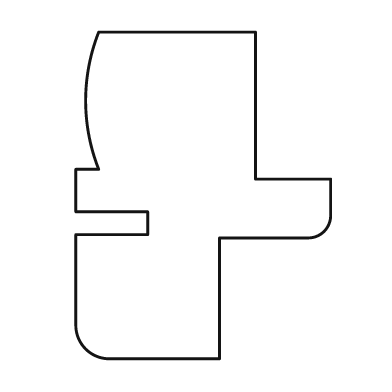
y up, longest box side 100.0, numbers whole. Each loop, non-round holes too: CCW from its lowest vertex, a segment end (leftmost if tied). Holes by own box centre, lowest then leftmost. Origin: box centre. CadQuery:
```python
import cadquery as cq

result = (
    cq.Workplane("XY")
    .moveTo(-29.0, -50.0)
    .lineTo(5.0, -50.0)
    .lineTo(5.0, -13.0)
    .lineTo(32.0, -13.0)
    .threePointArc((37.0, -11.0), (39.0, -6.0))
    .lineTo(39.0, 5.0)
    .lineTo(16.0, 5.0)
    .lineTo(16.0, 50.0)
    .lineTo(-32.0, 50.0)
    .threePointArc((-36.0, 29.0), (-32.0, 8.0))
    .lineTo(-39.0, 8.0)
    .lineTo(-39.0, -5.0)
    .lineTo(-17.0, -5.0)
    .lineTo(-17.0, -12.0)
    .lineTo(-39.0, -12.0)
    .lineTo(-39.0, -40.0)
    .threePointArc((-36.0, -47.0), (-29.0, -50.0))
    .close()
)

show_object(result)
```